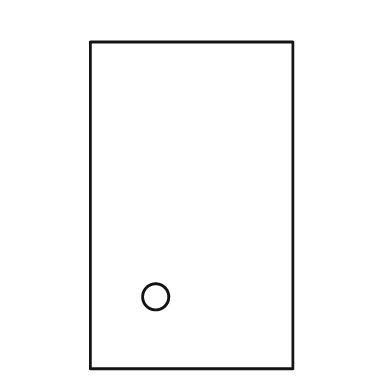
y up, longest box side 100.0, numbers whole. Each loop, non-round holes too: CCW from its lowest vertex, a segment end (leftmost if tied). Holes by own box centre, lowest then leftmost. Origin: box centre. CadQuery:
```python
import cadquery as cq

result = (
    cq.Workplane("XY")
    .moveTo(-31.0, -50.0)
    .lineTo(31.0, -50.0)
    .lineTo(31.0, 50.0)
    .lineTo(-31.0, 50.0)
    .close()
    .moveTo(-11.0, -28.0)
    .circle(4.0)
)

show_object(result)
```